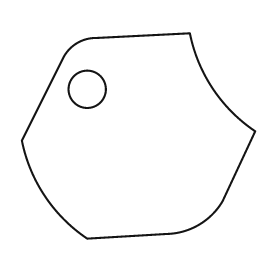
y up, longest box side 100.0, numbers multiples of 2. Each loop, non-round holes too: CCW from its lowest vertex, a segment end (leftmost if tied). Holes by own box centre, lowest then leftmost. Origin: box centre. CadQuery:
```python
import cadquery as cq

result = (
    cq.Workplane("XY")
    .moveTo(-22.0, -44.0)
    .lineTo(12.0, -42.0)
    .threePointArc((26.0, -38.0), (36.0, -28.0))
    .lineTo(50.0, 2.0)
    .threePointArc((32.0, 20.0), (22.0, 44.0))
    .lineTo(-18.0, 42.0)
    .threePointArc((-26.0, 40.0), (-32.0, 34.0))
    .lineTo(-50.0, -2.0)
    .threePointArc((-40.0, -26.0), (-22.0, -44.0))
    .close()
    .moveTo(-22.0, 20.0)
    .circle(8.0)
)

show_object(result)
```